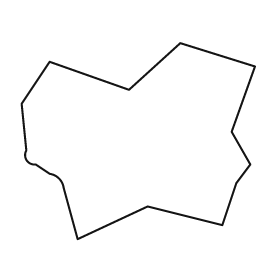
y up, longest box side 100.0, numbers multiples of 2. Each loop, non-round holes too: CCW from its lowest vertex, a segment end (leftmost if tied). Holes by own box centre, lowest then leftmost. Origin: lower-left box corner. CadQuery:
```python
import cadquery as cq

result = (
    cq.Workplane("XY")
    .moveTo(24.0, 0.0)
    .lineTo(54.0, 14.0)
    .lineTo(86.0, 6.0)
    .lineTo(92.0, 24.0)
    .lineTo(98.0, 32.0)
    .lineTo(90.0, 46.0)
    .lineTo(100.0, 74.0)
    .lineTo(68.0, 84.0)
    .lineTo(46.0, 64.0)
    .lineTo(12.0, 76.0)
    .lineTo(0.0, 58.0)
    .lineTo(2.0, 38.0)
    .threePointArc((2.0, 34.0), (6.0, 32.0))
    .lineTo(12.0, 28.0)
    .threePointArc((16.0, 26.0), (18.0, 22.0))
    .close()
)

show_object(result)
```